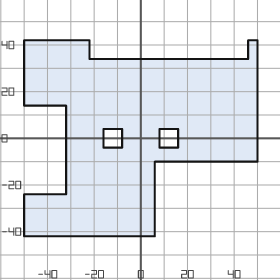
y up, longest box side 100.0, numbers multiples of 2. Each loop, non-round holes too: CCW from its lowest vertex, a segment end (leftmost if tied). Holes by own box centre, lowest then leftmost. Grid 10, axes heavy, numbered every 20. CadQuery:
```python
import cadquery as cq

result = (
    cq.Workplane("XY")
    .moveTo(-50.0, -42.0)
    .lineTo(6.0, -42.0)
    .lineTo(6.0, -10.0)
    .lineTo(50.0, -10.0)
    .lineTo(50.0, 42.0)
    .lineTo(46.0, 42.0)
    .lineTo(46.0, 34.0)
    .lineTo(-22.0, 34.0)
    .lineTo(-22.0, 42.0)
    .lineTo(-50.0, 42.0)
    .lineTo(-50.0, 14.0)
    .lineTo(-32.0, 14.0)
    .lineTo(-32.0, -24.0)
    .lineTo(-50.0, -24.0)
    .close()
    .moveTo(-16.0, -4.0)
    .lineTo(-8.0, -4.0)
    .lineTo(-8.0, 4.0)
    .lineTo(-16.0, 4.0)
    .close()
    .moveTo(8.0, -4.0)
    .lineTo(16.0, -4.0)
    .lineTo(16.0, 4.0)
    .lineTo(8.0, 4.0)
    .close()
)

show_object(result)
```